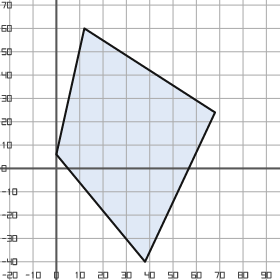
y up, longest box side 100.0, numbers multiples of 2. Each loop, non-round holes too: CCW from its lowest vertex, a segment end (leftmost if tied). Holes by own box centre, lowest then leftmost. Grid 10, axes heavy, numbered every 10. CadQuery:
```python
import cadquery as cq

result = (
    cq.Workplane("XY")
    .moveTo(38.0, -40.0)
    .lineTo(68.0, 24.0)
    .lineTo(12.0, 60.0)
    .lineTo(0.0, 6.0)
    .close()
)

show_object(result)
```